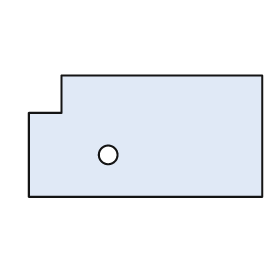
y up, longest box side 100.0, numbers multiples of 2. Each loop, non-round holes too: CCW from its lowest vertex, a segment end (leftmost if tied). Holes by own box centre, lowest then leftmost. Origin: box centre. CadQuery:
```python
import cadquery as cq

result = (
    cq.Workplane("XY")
    .moveTo(-50.0, -26.0)
    .lineTo(50.0, -26.0)
    .lineTo(50.0, 26.0)
    .lineTo(-36.0, 26.0)
    .lineTo(-36.0, 10.0)
    .lineTo(-50.0, 10.0)
    .close()
    .moveTo(-16.0, -8.0)
    .circle(4.0)
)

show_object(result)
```